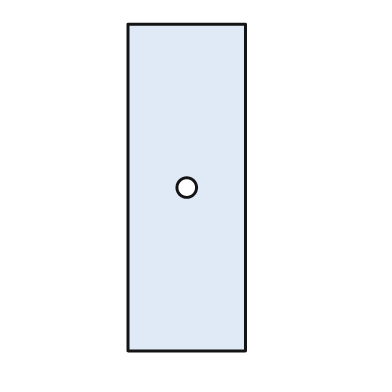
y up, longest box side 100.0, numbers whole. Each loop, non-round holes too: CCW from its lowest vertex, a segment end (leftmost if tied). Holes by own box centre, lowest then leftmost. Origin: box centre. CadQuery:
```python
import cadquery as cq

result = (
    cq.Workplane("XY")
    .moveTo(-18.0, -50.0)
    .lineTo(18.0, -50.0)
    .lineTo(18.0, 50.0)
    .lineTo(-18.0, 50.0)
    .close()
    .moveTo(0.0, 0.0)
    .circle(3.0)
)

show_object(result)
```